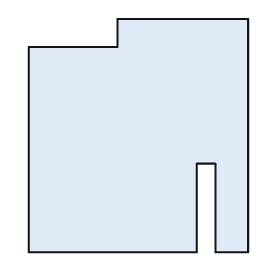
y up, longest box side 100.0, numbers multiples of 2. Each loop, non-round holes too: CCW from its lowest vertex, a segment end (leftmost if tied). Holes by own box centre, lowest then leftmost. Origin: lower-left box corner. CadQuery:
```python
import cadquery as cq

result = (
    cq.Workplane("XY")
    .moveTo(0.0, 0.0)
    .lineTo(72.0, 0.0)
    .lineTo(72.0, 38.0)
    .lineTo(80.0, 38.0)
    .lineTo(80.0, 0.0)
    .lineTo(94.0, 0.0)
    .lineTo(94.0, 100.0)
    .lineTo(38.0, 100.0)
    .lineTo(38.0, 88.0)
    .lineTo(0.0, 88.0)
    .close()
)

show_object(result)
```